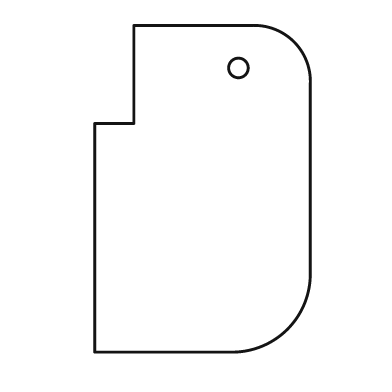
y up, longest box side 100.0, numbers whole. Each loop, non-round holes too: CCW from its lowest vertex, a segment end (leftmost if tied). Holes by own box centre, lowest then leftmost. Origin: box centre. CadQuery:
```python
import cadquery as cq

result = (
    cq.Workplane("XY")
    .moveTo(-33.0, -50.0)
    .lineTo(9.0, -50.0)
    .threePointArc((26.0, -43.0), (33.0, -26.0))
    .lineTo(33.0, 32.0)
    .threePointArc((28.0, 45.0), (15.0, 50.0))
    .lineTo(-21.0, 50.0)
    .lineTo(-21.0, 20.0)
    .lineTo(-33.0, 20.0)
    .close()
    .moveTo(11.0, 37.0)
    .circle(3.0)
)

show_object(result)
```